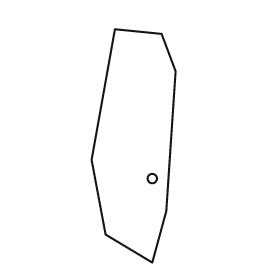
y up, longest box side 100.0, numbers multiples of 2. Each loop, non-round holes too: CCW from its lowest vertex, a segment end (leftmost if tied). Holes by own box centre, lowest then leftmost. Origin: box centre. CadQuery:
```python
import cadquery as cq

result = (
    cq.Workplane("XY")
    .moveTo(8.0, -50.0)
    .lineTo(14.0, -28.0)
    .lineTo(18.0, 32.0)
    .lineTo(12.0, 48.0)
    .lineTo(-8.0, 50.0)
    .lineTo(-18.0, -6.0)
    .lineTo(-12.0, -38.0)
    .close()
    .moveTo(8.0, -14.0)
    .circle(2.0)
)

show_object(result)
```